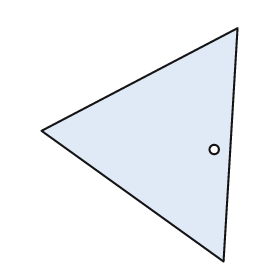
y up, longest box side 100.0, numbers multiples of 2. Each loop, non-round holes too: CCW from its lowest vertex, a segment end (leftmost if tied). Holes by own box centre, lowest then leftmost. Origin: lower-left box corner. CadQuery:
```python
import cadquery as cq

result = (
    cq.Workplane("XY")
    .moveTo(78.0, 0.0)
    .lineTo(84.0, 100.0)
    .lineTo(0.0, 56.0)
    .close()
    .moveTo(74.0, 48.0)
    .circle(2.0)
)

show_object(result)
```